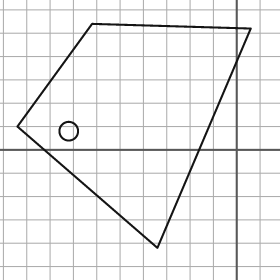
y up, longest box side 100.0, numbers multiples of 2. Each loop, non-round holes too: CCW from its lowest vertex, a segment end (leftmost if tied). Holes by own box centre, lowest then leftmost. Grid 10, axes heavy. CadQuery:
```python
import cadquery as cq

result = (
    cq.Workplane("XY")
    .moveTo(-34.0, -42.0)
    .lineTo(6.0, 52.0)
    .lineTo(-62.0, 54.0)
    .lineTo(-94.0, 10.0)
    .close()
    .moveTo(-72.0, 8.0)
    .circle(4.0)
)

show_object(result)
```